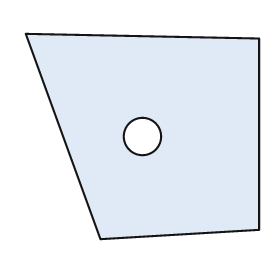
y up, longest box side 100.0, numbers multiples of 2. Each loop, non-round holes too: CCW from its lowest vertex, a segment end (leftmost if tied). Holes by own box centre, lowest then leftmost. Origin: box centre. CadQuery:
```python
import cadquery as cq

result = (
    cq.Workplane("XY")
    .moveTo(-18.0, -44.0)
    .lineTo(50.0, -40.0)
    .lineTo(50.0, 42.0)
    .lineTo(-50.0, 44.0)
    .close()
    .moveTo(0.0, 0.0)
    .circle(8.0)
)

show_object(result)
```